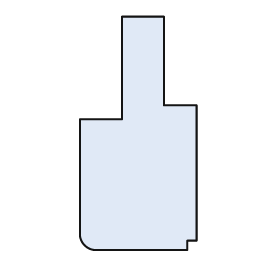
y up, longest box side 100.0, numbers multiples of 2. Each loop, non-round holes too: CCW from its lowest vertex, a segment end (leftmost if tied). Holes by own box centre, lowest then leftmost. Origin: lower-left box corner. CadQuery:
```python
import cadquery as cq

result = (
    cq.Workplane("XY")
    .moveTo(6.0, 0.0)
    .lineTo(46.0, 0.0)
    .lineTo(46.0, 4.0)
    .lineTo(50.0, 4.0)
    .lineTo(50.0, 62.0)
    .lineTo(36.0, 62.0)
    .lineTo(36.0, 100.0)
    .lineTo(18.0, 100.0)
    .lineTo(18.0, 56.0)
    .lineTo(0.0, 56.0)
    .lineTo(0.0, 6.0)
    .threePointArc((2.0, 2.0), (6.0, 0.0))
    .close()
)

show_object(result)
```